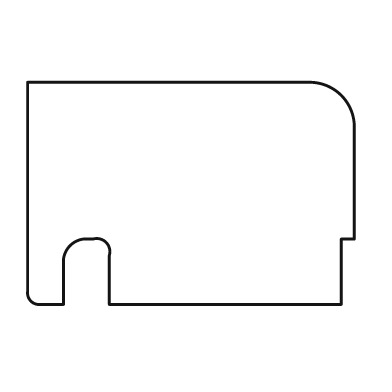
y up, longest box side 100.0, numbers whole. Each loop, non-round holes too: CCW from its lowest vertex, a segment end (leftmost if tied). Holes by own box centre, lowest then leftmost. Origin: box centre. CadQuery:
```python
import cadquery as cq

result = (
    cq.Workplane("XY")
    .moveTo(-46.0, -34.0)
    .lineTo(-39.0, -34.0)
    .lineTo(-39.0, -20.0)
    .threePointArc((-37.0, -16.0), (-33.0, -14.0))
    .lineTo(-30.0, -14.0)
    .threePointArc((-26.0, -15.0), (-25.0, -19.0))
    .lineTo(-25.0, -34.0)
    .lineTo(46.0, -34.0)
    .lineTo(46.0, -14.0)
    .lineTo(50.0, -14.0)
    .lineTo(50.0, 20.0)
    .threePointArc((46.0, 30.0), (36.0, 34.0))
    .lineTo(-50.0, 34.0)
    .lineTo(-50.0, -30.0)
    .threePointArc((-49.0, -33.0), (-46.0, -34.0))
    .close()
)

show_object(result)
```